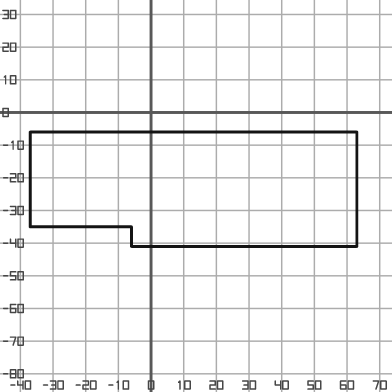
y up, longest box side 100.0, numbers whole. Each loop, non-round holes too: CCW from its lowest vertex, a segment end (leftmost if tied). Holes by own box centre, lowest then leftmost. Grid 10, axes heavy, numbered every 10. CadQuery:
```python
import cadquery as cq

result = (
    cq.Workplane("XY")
    .moveTo(-6.0, -41.0)
    .lineTo(63.0, -41.0)
    .lineTo(63.0, -6.0)
    .lineTo(-37.0, -6.0)
    .lineTo(-37.0, -35.0)
    .lineTo(-6.0, -35.0)
    .close()
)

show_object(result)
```